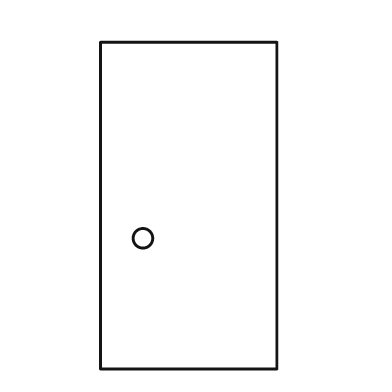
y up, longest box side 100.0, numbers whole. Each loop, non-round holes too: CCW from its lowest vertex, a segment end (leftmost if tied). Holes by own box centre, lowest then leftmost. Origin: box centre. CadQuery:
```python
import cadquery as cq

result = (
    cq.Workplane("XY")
    .moveTo(-27.0, -50.0)
    .lineTo(27.0, -50.0)
    .lineTo(27.0, 50.0)
    .lineTo(-27.0, 50.0)
    .close()
    .moveTo(-14.0, -10.0)
    .circle(3.0)
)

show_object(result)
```